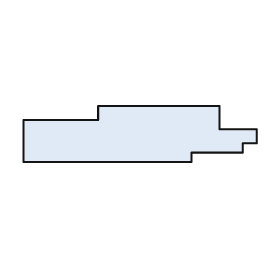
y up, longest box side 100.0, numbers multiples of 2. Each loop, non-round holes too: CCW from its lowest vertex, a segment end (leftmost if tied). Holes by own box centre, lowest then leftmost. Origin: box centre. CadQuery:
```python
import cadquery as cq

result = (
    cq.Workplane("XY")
    .moveTo(-50.0, -12.0)
    .lineTo(22.0, -12.0)
    .lineTo(22.0, -8.0)
    .lineTo(44.0, -8.0)
    .lineTo(44.0, -4.0)
    .lineTo(50.0, -4.0)
    .lineTo(50.0, 2.0)
    .lineTo(34.0, 2.0)
    .lineTo(34.0, 12.0)
    .lineTo(-18.0, 12.0)
    .lineTo(-18.0, 6.0)
    .lineTo(-50.0, 6.0)
    .close()
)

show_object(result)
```